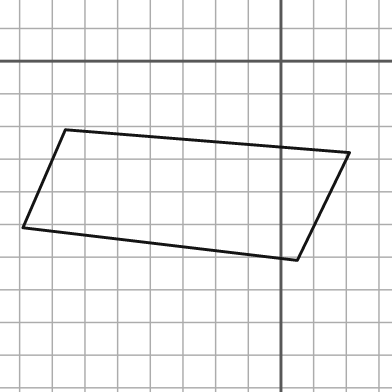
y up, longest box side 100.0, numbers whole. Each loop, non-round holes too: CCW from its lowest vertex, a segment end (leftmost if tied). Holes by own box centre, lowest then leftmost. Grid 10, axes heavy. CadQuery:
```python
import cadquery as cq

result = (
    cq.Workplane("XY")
    .moveTo(5.0, -61.0)
    .lineTo(21.0, -28.0)
    .lineTo(-66.0, -21.0)
    .lineTo(-79.0, -51.0)
    .close()
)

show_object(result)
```